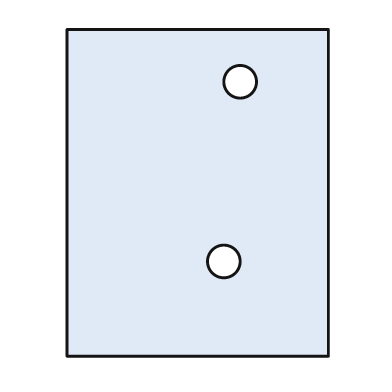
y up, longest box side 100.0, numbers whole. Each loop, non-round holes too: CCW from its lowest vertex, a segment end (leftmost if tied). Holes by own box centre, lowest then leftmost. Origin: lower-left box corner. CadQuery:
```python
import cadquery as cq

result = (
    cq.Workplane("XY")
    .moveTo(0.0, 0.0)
    .lineTo(80.0, 0.0)
    .lineTo(80.0, 100.0)
    .lineTo(0.0, 100.0)
    .close()
    .moveTo(48.0, 29.0)
    .circle(5.0)
    .moveTo(53.0, 84.0)
    .circle(5.0)
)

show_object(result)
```